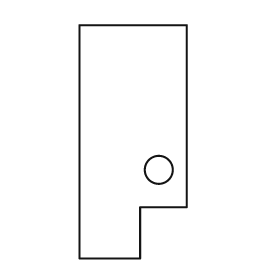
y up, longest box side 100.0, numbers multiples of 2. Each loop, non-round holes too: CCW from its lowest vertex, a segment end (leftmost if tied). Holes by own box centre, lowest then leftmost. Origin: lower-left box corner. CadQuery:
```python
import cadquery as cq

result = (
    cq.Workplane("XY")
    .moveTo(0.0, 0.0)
    .lineTo(26.0, 0.0)
    .lineTo(26.0, 22.0)
    .lineTo(46.0, 22.0)
    .lineTo(46.0, 100.0)
    .lineTo(0.0, 100.0)
    .close()
    .moveTo(34.0, 38.0)
    .circle(6.0)
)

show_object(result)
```